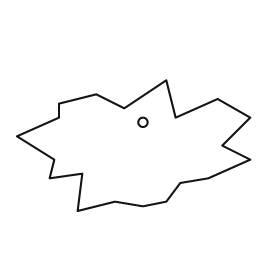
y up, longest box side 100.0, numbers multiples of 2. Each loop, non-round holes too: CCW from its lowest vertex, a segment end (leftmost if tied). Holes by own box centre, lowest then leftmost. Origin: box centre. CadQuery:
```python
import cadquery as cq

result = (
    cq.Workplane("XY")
    .moveTo(-24.0, -28.0)
    .lineTo(-8.0, -24.0)
    .lineTo(4.0, -26.0)
    .lineTo(14.0, -24.0)
    .lineTo(20.0, -16.0)
    .lineTo(32.0, -14.0)
    .lineTo(50.0, -6.0)
    .lineTo(38.0, 0.0)
    .lineTo(50.0, 12.0)
    .lineTo(36.0, 20.0)
    .lineTo(18.0, 12.0)
    .lineTo(14.0, 28.0)
    .lineTo(-4.0, 16.0)
    .lineTo(-16.0, 22.0)
    .lineTo(-32.0, 18.0)
    .lineTo(-32.0, 12.0)
    .lineTo(-50.0, 4.0)
    .lineTo(-34.0, -6.0)
    .lineTo(-36.0, -14.0)
    .lineTo(-22.0, -12.0)
    .close()
    .moveTo(4.0, 10.0)
    .circle(2.0)
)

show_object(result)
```